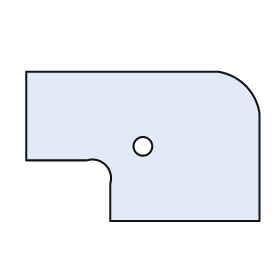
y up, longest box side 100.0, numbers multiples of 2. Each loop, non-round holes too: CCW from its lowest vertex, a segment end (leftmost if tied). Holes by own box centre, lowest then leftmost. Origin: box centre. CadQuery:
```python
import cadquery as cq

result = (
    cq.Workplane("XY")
    .moveTo(-14.0, -32.0)
    .lineTo(50.0, -32.0)
    .lineTo(50.0, 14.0)
    .threePointArc((44.0, 26.0), (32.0, 32.0))
    .lineTo(-50.0, 32.0)
    .lineTo(-50.0, -6.0)
    .lineTo(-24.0, -6.0)
    .threePointArc((-16.0, -8.0), (-14.0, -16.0))
    .close()
    .moveTo(0.0, 0.0)
    .circle(4.0)
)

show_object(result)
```